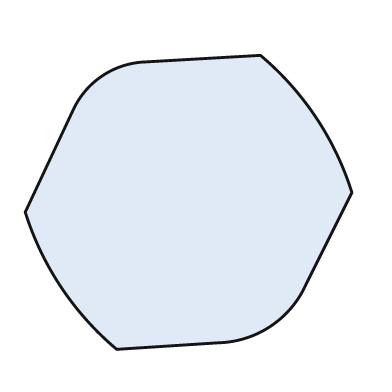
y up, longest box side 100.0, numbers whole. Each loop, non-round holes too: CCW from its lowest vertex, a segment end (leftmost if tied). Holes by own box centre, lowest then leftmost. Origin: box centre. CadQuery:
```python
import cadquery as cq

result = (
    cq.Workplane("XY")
    .moveTo(-22.0, -45.0)
    .lineTo(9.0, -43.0)
    .threePointArc((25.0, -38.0), (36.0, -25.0))
    .lineTo(50.0, 3.0)
    .threePointArc((39.0, 26.0), (22.0, 45.0))
    .lineTo(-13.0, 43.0)
    .threePointArc((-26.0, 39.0), (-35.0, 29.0))
    .lineTo(-50.0, -3.0)
    .threePointArc((-39.0, -26.0), (-22.0, -45.0))
    .close()
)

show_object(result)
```